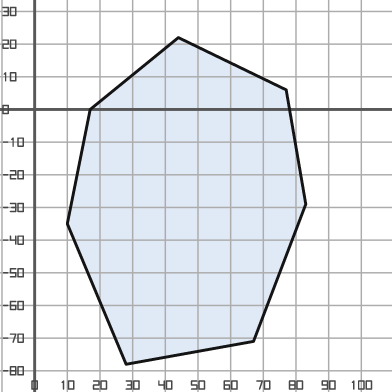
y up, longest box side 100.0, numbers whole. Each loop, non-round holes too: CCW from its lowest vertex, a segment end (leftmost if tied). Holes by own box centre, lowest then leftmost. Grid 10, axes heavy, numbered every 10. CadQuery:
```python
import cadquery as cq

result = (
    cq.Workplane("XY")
    .moveTo(28.0, -78.0)
    .lineTo(67.0, -71.0)
    .lineTo(83.0, -29.0)
    .lineTo(77.0, 6.0)
    .lineTo(44.0, 22.0)
    .lineTo(17.0, 0.0)
    .lineTo(10.0, -35.0)
    .close()
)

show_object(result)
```